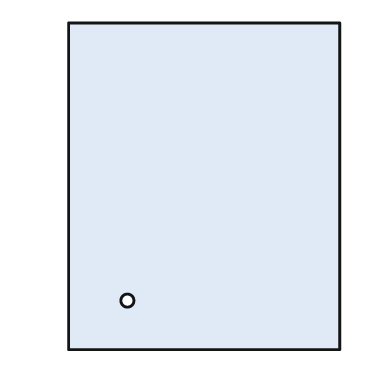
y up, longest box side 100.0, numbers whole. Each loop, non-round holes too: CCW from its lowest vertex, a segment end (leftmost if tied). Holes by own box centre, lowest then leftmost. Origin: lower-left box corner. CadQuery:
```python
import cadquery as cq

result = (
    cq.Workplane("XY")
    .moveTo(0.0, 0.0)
    .lineTo(83.0, 0.0)
    .lineTo(83.0, 100.0)
    .lineTo(0.0, 100.0)
    .close()
    .moveTo(18.0, 15.0)
    .circle(2.0)
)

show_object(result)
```